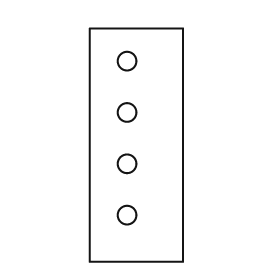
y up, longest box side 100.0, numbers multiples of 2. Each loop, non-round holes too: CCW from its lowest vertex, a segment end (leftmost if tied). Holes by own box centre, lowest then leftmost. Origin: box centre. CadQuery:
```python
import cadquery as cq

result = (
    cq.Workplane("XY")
    .moveTo(-20.0, -50.0)
    .lineTo(20.0, -50.0)
    .lineTo(20.0, 50.0)
    .lineTo(-20.0, 50.0)
    .close()
    .moveTo(-4.0, -30.0)
    .circle(4.0)
    .moveTo(-4.0, -8.0)
    .circle(4.0)
    .moveTo(-4.0, 14.0)
    .circle(4.0)
    .moveTo(-4.0, 36.0)
    .circle(4.0)
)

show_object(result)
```